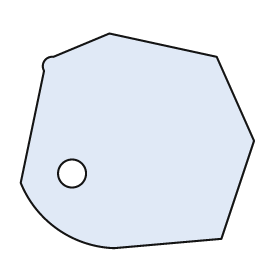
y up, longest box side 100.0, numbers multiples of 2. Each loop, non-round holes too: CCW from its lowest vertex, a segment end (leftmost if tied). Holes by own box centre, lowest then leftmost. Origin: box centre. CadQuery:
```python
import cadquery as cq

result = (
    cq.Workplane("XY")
    .moveTo(-10.0, -46.0)
    .lineTo(36.0, -42.0)
    .lineTo(50.0, 0.0)
    .lineTo(34.0, 36.0)
    .lineTo(-12.0, 46.0)
    .lineTo(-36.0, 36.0)
    .threePointArc((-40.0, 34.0), (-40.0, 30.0))
    .lineTo(-50.0, -18.0)
    .threePointArc((-34.0, -38.0), (-10.0, -46.0))
    .close()
    .moveTo(-28.0, -14.0)
    .circle(6.0)
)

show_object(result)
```